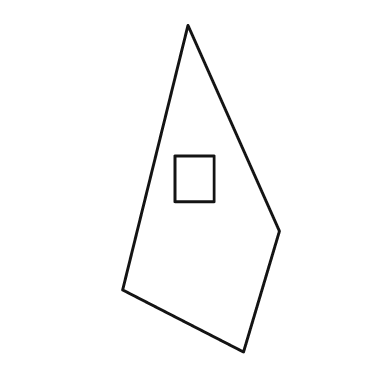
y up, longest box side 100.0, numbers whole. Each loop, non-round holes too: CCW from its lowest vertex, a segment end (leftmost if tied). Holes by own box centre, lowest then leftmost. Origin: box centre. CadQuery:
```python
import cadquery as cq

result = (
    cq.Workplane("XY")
    .moveTo(13.0, -50.0)
    .lineTo(24.0, -13.0)
    .lineTo(-4.0, 50.0)
    .lineTo(-24.0, -31.0)
    .close()
    .moveTo(-8.0, -4.0)
    .lineTo(4.0, -4.0)
    .lineTo(4.0, 10.0)
    .lineTo(-8.0, 10.0)
    .close()
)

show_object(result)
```